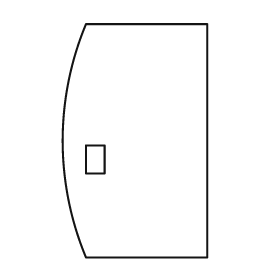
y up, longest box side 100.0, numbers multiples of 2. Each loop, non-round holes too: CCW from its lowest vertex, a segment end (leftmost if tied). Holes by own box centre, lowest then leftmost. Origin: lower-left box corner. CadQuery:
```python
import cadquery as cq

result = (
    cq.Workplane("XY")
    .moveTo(10.0, 0.0)
    .lineTo(62.0, 0.0)
    .lineTo(62.0, 100.0)
    .lineTo(10.0, 100.0)
    .threePointArc((0.0, 50.0), (10.0, 0.0))
    .close()
    .moveTo(10.0, 36.0)
    .lineTo(18.0, 36.0)
    .lineTo(18.0, 48.0)
    .lineTo(10.0, 48.0)
    .close()
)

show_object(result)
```